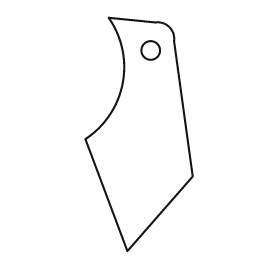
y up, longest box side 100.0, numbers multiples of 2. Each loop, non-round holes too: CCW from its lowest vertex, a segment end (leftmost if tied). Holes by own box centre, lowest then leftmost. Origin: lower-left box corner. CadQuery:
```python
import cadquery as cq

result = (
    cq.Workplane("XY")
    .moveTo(18.0, 0.0)
    .lineTo(46.0, 32.0)
    .lineTo(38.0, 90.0)
    .threePointArc((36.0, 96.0), (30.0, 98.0))
    .lineTo(10.0, 100.0)
    .threePointArc((16.0, 72.0), (0.0, 48.0))
    .close()
    .moveTo(28.0, 86.0)
    .circle(4.0)
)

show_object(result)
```